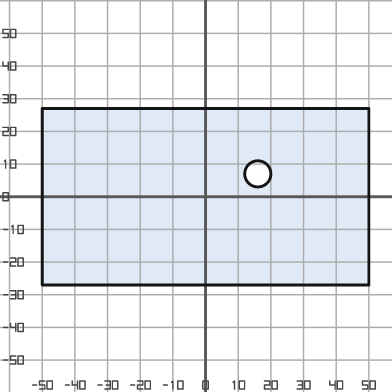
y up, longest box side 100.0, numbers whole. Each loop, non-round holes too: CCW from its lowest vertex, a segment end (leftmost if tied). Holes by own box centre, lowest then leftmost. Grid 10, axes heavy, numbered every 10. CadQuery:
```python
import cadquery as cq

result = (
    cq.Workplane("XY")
    .moveTo(-50.0, -27.0)
    .lineTo(50.0, -27.0)
    .lineTo(50.0, 27.0)
    .lineTo(-50.0, 27.0)
    .close()
    .moveTo(16.0, 7.0)
    .circle(4.0)
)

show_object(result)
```